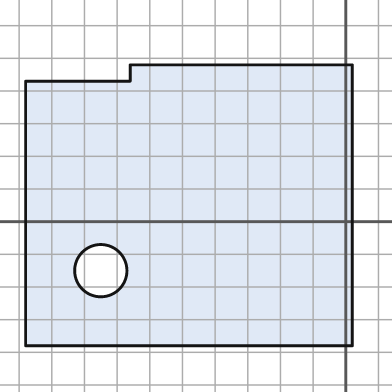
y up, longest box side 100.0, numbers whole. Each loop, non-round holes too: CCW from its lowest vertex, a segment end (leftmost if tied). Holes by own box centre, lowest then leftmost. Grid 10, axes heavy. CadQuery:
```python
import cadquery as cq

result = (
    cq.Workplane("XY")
    .moveTo(-98.0, -38.0)
    .lineTo(2.0, -38.0)
    .lineTo(2.0, 48.0)
    .lineTo(-66.0, 48.0)
    .lineTo(-66.0, 43.0)
    .lineTo(-98.0, 43.0)
    .close()
    .moveTo(-75.0, -15.0)
    .circle(8.0)
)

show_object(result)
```